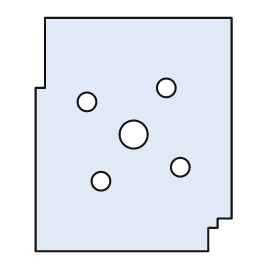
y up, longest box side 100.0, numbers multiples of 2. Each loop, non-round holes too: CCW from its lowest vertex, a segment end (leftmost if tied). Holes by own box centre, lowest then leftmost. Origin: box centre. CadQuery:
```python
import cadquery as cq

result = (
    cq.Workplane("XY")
    .moveTo(-42.0, -50.0)
    .lineTo(32.0, -50.0)
    .lineTo(32.0, -40.0)
    .lineTo(36.0, -40.0)
    .lineTo(36.0, -36.0)
    .lineTo(42.0, -36.0)
    .lineTo(42.0, 50.0)
    .lineTo(-38.0, 50.0)
    .lineTo(-38.0, 20.0)
    .lineTo(-42.0, 20.0)
    .close()
    .moveTo(-14.0, -20.0)
    .circle(4.0)
    .moveTo(20.0, -14.0)
    .circle(4.0)
    .moveTo(0.0, 0.0)
    .circle(6.0)
    .moveTo(-20.0, 14.0)
    .circle(4.0)
    .moveTo(14.0, 20.0)
    .circle(4.0)
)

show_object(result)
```